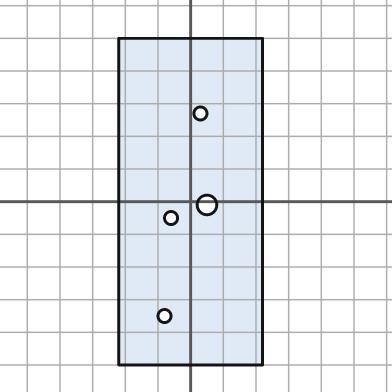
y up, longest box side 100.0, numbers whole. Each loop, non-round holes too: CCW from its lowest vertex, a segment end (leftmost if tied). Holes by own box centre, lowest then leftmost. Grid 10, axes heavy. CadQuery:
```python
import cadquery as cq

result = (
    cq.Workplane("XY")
    .moveTo(-22.0, -50.0)
    .lineTo(22.0, -50.0)
    .lineTo(22.0, 50.0)
    .lineTo(-22.0, 50.0)
    .close()
    .moveTo(-8.0, -35.0)
    .circle(2.0)
    .moveTo(-6.0, -5.0)
    .circle(2.0)
    .moveTo(5.0, -1.0)
    .circle(3.0)
    .moveTo(3.0, 27.0)
    .circle(2.0)
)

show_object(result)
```